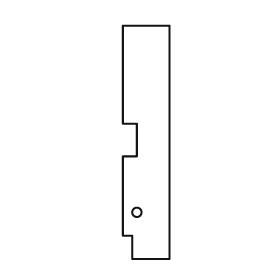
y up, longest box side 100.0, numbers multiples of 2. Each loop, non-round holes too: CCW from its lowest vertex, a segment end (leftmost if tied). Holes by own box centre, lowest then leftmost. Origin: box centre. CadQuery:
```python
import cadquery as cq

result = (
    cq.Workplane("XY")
    .moveTo(-6.0, -50.0)
    .lineTo(10.0, -50.0)
    .lineTo(10.0, 50.0)
    .lineTo(-10.0, 50.0)
    .lineTo(-10.0, 8.0)
    .lineTo(-4.0, 8.0)
    .lineTo(-4.0, -6.0)
    .lineTo(-10.0, -6.0)
    .lineTo(-10.0, -40.0)
    .lineTo(-6.0, -40.0)
    .close()
    .moveTo(-4.0, -30.0)
    .circle(2.0)
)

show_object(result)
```